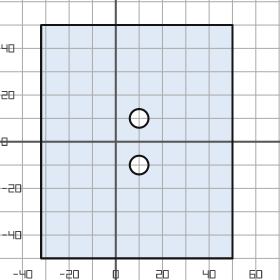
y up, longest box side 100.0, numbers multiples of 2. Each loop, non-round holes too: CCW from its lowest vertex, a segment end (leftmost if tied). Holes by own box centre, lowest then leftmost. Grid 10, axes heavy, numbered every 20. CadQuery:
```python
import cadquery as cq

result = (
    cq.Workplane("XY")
    .moveTo(-32.0, -50.0)
    .lineTo(50.0, -50.0)
    .lineTo(50.0, 50.0)
    .lineTo(-32.0, 50.0)
    .close()
    .moveTo(10.0, -10.0)
    .circle(4.0)
    .moveTo(10.0, 10.0)
    .circle(4.0)
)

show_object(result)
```